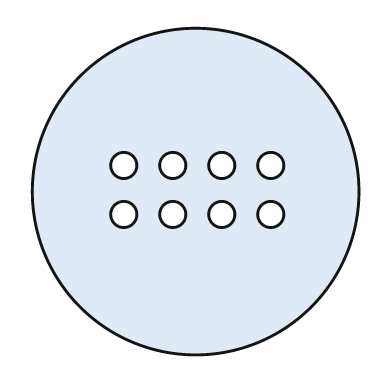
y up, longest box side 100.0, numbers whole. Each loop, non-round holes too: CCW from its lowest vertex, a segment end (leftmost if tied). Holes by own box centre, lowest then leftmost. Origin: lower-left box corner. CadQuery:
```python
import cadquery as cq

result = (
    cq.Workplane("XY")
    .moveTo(50.0, 50.0)
    .circle(50.0)
    .moveTo(28.0, 43.0)
    .circle(4.0)
    .moveTo(43.0, 43.0)
    .circle(4.0)
    .moveTo(58.0, 43.0)
    .circle(4.0)
    .moveTo(73.0, 43.0)
    .circle(4.0)
    .moveTo(28.0, 58.0)
    .circle(4.0)
    .moveTo(43.0, 58.0)
    .circle(4.0)
    .moveTo(58.0, 58.0)
    .circle(4.0)
    .moveTo(73.0, 58.0)
    .circle(4.0)
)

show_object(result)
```